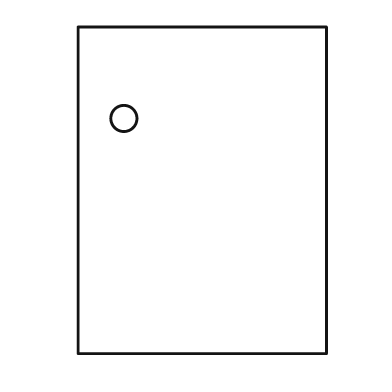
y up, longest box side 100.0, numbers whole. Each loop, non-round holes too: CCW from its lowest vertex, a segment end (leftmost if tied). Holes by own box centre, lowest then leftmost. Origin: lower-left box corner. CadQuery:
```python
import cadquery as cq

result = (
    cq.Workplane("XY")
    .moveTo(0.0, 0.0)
    .lineTo(76.0, 0.0)
    .lineTo(76.0, 100.0)
    .lineTo(0.0, 100.0)
    .close()
    .moveTo(14.0, 72.0)
    .circle(4.0)
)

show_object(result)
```